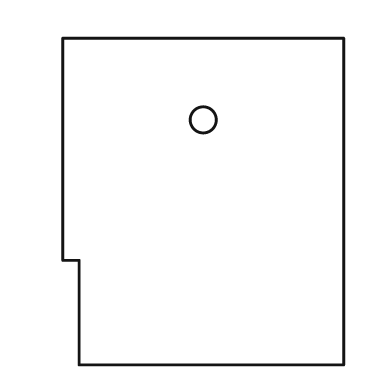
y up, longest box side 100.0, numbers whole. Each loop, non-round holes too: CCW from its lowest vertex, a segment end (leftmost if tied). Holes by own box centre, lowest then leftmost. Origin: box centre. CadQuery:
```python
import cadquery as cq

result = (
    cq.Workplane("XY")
    .moveTo(-38.0, -50.0)
    .lineTo(43.0, -50.0)
    .lineTo(43.0, 50.0)
    .lineTo(-43.0, 50.0)
    .lineTo(-43.0, -18.0)
    .lineTo(-38.0, -18.0)
    .close()
    .moveTo(0.0, 25.0)
    .circle(4.0)
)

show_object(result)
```